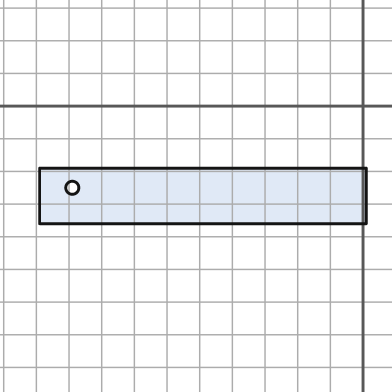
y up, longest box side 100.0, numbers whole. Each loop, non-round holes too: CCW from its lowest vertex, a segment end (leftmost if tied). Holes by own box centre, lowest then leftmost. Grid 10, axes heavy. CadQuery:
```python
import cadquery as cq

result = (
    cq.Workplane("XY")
    .moveTo(-99.0, -36.0)
    .lineTo(1.0, -36.0)
    .lineTo(1.0, -19.0)
    .lineTo(-99.0, -19.0)
    .close()
    .moveTo(-89.0, -25.0)
    .circle(2.0)
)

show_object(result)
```